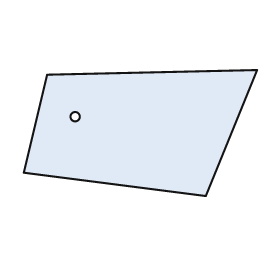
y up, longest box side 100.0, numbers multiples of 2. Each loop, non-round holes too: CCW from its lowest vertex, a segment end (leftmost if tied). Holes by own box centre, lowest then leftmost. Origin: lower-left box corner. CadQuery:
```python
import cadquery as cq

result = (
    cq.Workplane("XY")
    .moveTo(78.0, 0.0)
    .lineTo(100.0, 54.0)
    .lineTo(10.0, 52.0)
    .lineTo(0.0, 10.0)
    .close()
    .moveTo(22.0, 34.0)
    .circle(2.0)
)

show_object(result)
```